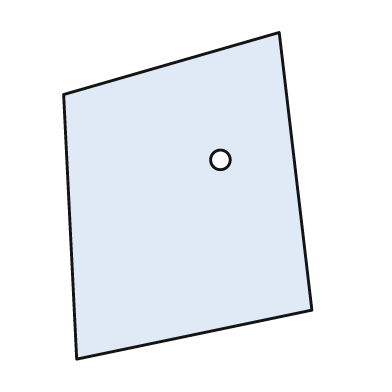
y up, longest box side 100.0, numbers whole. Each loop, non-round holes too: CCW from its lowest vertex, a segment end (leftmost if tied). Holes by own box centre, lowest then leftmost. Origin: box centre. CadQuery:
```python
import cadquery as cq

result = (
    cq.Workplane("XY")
    .moveTo(-34.0, -50.0)
    .lineTo(38.0, -35.0)
    .lineTo(28.0, 50.0)
    .lineTo(-38.0, 31.0)
    .close()
    .moveTo(10.0, 11.0)
    .circle(3.0)
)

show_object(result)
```